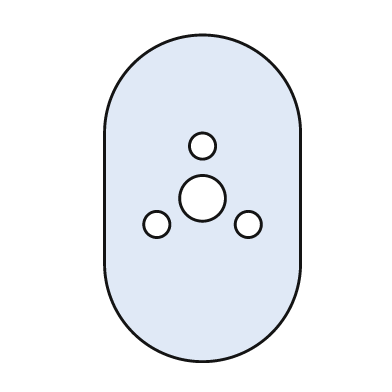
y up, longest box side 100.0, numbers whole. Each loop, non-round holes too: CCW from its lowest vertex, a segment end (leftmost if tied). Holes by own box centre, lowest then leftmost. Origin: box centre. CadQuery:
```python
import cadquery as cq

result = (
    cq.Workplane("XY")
    .moveTo(-30.0, -20.0)
    .threePointArc((0.0, -50.0), (30.0, -20.0))
    .lineTo(30.0, 20.0)
    .threePointArc((0.0, 50.0), (-30.0, 20.0))
    .close()
    .moveTo(-14.0, -8.0)
    .circle(4.0)
    .moveTo(14.0, -8.0)
    .circle(4.0)
    .moveTo(0.0, 0.0)
    .circle(7.0)
    .moveTo(0.0, 16.0)
    .circle(4.0)
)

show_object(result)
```